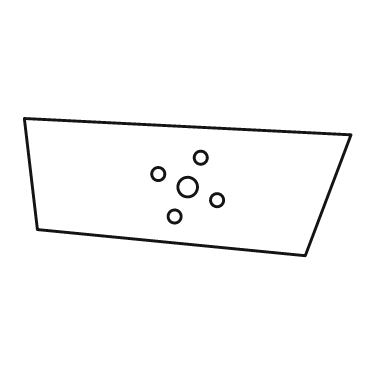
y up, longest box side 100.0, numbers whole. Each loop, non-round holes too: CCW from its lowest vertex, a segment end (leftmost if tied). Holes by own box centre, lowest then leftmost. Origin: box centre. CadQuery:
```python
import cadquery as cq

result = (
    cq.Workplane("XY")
    .moveTo(36.0, -21.0)
    .lineTo(50.0, 16.0)
    .lineTo(-50.0, 21.0)
    .lineTo(-46.0, -13.0)
    .close()
    .moveTo(-4.0, -9.0)
    .circle(2.0)
    .moveTo(9.0, -4.0)
    .circle(2.0)
    .moveTo(0.0, 0.0)
    .circle(3.0)
    .moveTo(-9.0, 4.0)
    .circle(2.0)
    .moveTo(4.0, 9.0)
    .circle(2.0)
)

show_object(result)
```